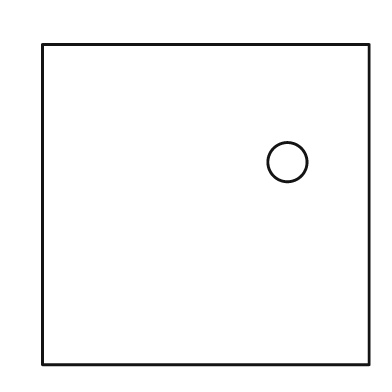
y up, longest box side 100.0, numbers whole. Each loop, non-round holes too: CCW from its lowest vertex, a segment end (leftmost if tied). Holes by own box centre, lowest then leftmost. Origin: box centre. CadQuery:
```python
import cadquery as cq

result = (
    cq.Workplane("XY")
    .moveTo(-50.0, -49.0)
    .lineTo(50.0, -49.0)
    .lineTo(50.0, 49.0)
    .lineTo(-50.0, 49.0)
    .close()
    .moveTo(25.0, 13.0)
    .circle(6.0)
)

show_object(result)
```